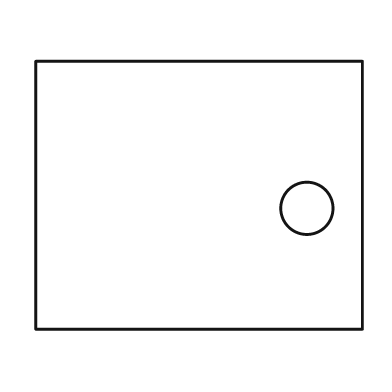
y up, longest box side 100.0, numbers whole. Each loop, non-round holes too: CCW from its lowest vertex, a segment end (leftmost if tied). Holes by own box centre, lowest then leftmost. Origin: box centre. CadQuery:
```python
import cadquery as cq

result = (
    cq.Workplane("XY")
    .moveTo(-50.0, -41.0)
    .lineTo(50.0, -41.0)
    .lineTo(50.0, 41.0)
    .lineTo(-50.0, 41.0)
    .close()
    .moveTo(33.0, -4.0)
    .circle(8.0)
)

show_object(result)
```